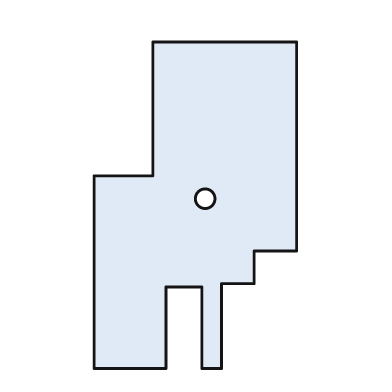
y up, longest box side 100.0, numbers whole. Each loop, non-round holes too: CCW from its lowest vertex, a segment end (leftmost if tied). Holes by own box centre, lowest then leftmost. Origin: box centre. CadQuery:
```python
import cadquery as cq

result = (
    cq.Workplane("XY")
    .moveTo(-31.0, -50.0)
    .lineTo(-9.0, -50.0)
    .lineTo(-9.0, -25.0)
    .lineTo(2.0, -25.0)
    .lineTo(2.0, -50.0)
    .lineTo(8.0, -50.0)
    .lineTo(8.0, -24.0)
    .lineTo(18.0, -24.0)
    .lineTo(18.0, -14.0)
    .lineTo(31.0, -14.0)
    .lineTo(31.0, 50.0)
    .lineTo(-13.0, 50.0)
    .lineTo(-13.0, 9.0)
    .lineTo(-31.0, 9.0)
    .close()
    .moveTo(3.0, 2.0)
    .circle(3.0)
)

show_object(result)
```